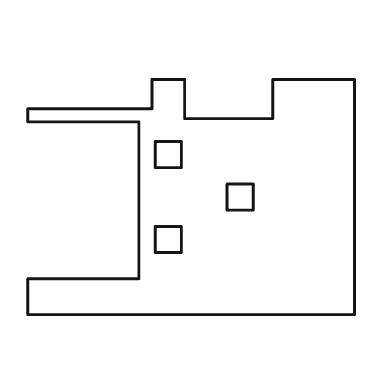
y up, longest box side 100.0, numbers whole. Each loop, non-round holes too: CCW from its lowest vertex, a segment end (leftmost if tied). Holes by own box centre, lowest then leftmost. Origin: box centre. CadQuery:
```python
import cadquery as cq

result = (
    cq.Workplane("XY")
    .moveTo(-50.0, -36.0)
    .lineTo(50.0, -36.0)
    .lineTo(50.0, 36.0)
    .lineTo(25.0, 36.0)
    .lineTo(25.0, 24.0)
    .lineTo(-2.0, 24.0)
    .lineTo(-2.0, 36.0)
    .lineTo(-12.0, 36.0)
    .lineTo(-12.0, 27.0)
    .lineTo(-50.0, 27.0)
    .lineTo(-50.0, 23.0)
    .lineTo(-16.0, 23.0)
    .lineTo(-16.0, -25.0)
    .lineTo(-50.0, -25.0)
    .close()
    .moveTo(-11.0, -17.0)
    .lineTo(-3.0, -17.0)
    .lineTo(-3.0, -9.0)
    .lineTo(-11.0, -9.0)
    .close()
    .moveTo(11.0, -4.0)
    .lineTo(19.0, -4.0)
    .lineTo(19.0, 4.0)
    .lineTo(11.0, 4.0)
    .close()
    .moveTo(-11.0, 9.0)
    .lineTo(-3.0, 9.0)
    .lineTo(-3.0, 17.0)
    .lineTo(-11.0, 17.0)
    .close()
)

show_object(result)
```